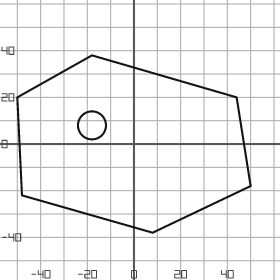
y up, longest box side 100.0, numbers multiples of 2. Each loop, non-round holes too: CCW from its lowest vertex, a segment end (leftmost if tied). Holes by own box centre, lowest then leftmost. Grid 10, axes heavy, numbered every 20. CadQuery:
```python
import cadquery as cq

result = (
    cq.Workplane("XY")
    .moveTo(8.0, -38.0)
    .lineTo(50.0, -18.0)
    .lineTo(44.0, 20.0)
    .lineTo(-18.0, 38.0)
    .lineTo(-50.0, 20.0)
    .lineTo(-48.0, -22.0)
    .close()
    .moveTo(-18.0, 8.0)
    .circle(6.0)
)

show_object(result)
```